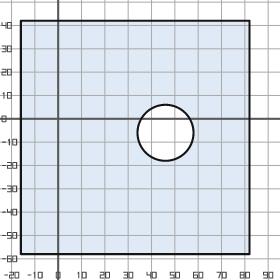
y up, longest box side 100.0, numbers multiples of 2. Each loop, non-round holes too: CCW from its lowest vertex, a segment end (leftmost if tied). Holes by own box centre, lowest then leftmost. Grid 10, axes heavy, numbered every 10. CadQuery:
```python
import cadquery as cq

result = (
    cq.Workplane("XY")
    .moveTo(-16.0, -58.0)
    .lineTo(82.0, -58.0)
    .lineTo(82.0, 42.0)
    .lineTo(-16.0, 42.0)
    .close()
    .moveTo(46.0, -6.0)
    .circle(12.0)
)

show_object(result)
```